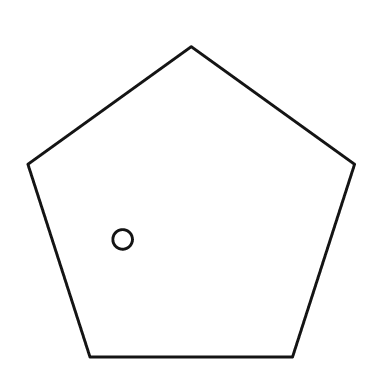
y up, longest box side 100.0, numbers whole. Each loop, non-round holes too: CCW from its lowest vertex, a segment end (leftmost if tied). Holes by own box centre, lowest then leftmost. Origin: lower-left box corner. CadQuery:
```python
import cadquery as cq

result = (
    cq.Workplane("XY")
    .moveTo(19.0, 0.0)
    .lineTo(81.0, 0.0)
    .lineTo(100.0, 59.0)
    .lineTo(50.0, 95.0)
    .lineTo(0.0, 59.0)
    .close()
    .moveTo(29.0, 36.0)
    .circle(3.0)
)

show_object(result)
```